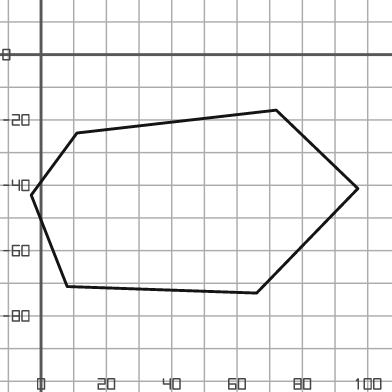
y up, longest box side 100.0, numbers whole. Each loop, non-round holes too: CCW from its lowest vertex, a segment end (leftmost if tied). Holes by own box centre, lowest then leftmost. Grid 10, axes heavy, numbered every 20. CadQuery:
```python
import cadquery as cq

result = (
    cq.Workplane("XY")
    .moveTo(66.0, -73.0)
    .lineTo(97.0, -41.0)
    .lineTo(72.0, -17.0)
    .lineTo(11.0, -24.0)
    .lineTo(-3.0, -43.0)
    .lineTo(8.0, -71.0)
    .close()
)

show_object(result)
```